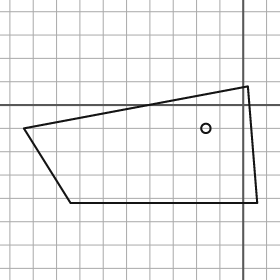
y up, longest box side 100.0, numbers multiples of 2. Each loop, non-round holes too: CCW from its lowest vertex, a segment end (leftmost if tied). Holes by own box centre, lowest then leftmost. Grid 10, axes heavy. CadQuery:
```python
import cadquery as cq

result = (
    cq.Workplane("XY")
    .moveTo(-74.0, -42.0)
    .lineTo(6.0, -42.0)
    .lineTo(2.0, 8.0)
    .lineTo(-94.0, -10.0)
    .close()
    .moveTo(-16.0, -10.0)
    .circle(2.0)
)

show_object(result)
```